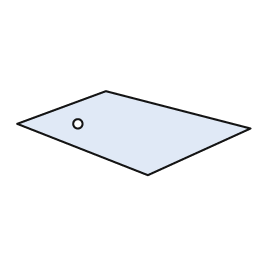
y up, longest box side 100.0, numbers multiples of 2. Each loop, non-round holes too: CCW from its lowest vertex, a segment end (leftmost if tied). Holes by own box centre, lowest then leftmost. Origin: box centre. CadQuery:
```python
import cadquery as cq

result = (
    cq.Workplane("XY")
    .moveTo(6.0, -18.0)
    .lineTo(50.0, 2.0)
    .lineTo(-12.0, 18.0)
    .lineTo(-50.0, 4.0)
    .close()
    .moveTo(-24.0, 4.0)
    .circle(2.0)
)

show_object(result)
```